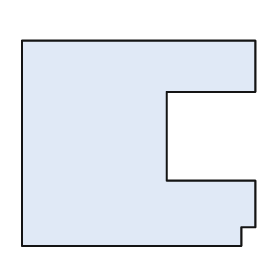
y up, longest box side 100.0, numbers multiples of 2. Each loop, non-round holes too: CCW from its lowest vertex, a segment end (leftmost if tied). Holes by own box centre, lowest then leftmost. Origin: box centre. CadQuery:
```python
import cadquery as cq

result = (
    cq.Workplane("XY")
    .moveTo(-50.0, -44.0)
    .lineTo(44.0, -44.0)
    .lineTo(44.0, -36.0)
    .lineTo(50.0, -36.0)
    .lineTo(50.0, -16.0)
    .lineTo(12.0, -16.0)
    .lineTo(12.0, 22.0)
    .lineTo(50.0, 22.0)
    .lineTo(50.0, 44.0)
    .lineTo(-50.0, 44.0)
    .close()
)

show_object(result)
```